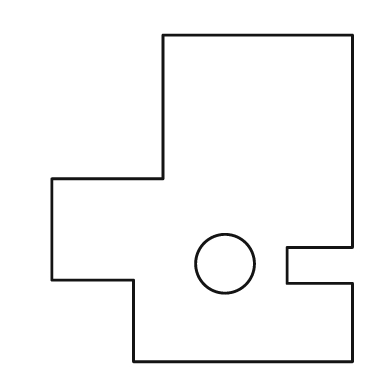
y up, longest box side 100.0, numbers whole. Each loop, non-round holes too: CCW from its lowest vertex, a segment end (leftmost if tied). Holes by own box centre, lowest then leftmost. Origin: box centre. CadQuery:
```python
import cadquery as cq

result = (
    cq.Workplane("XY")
    .moveTo(-21.0, -50.0)
    .lineTo(46.0, -50.0)
    .lineTo(46.0, -26.0)
    .lineTo(26.0, -26.0)
    .lineTo(26.0, -15.0)
    .lineTo(46.0, -15.0)
    .lineTo(46.0, 50.0)
    .lineTo(-12.0, 50.0)
    .lineTo(-12.0, 6.0)
    .lineTo(-46.0, 6.0)
    .lineTo(-46.0, -25.0)
    .lineTo(-21.0, -25.0)
    .close()
    .moveTo(7.0, -20.0)
    .circle(9.0)
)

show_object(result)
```